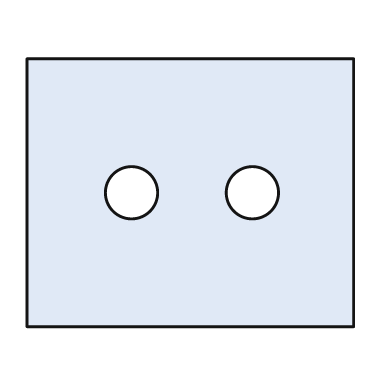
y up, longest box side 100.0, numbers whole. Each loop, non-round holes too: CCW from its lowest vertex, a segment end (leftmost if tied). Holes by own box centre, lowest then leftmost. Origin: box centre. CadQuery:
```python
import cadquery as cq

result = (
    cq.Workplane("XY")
    .moveTo(-50.0, -41.0)
    .lineTo(50.0, -41.0)
    .lineTo(50.0, 41.0)
    .lineTo(-50.0, 41.0)
    .close()
    .moveTo(-18.0, 0.0)
    .circle(8.0)
    .moveTo(19.0, 0.0)
    .circle(8.0)
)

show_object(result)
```